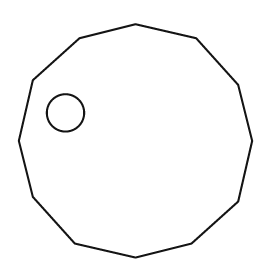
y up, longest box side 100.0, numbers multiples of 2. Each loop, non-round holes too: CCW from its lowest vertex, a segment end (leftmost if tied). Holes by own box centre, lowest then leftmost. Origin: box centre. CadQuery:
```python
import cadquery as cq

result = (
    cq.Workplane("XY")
    .moveTo(0.0, -50.0)
    .lineTo(24.0, -44.0)
    .lineTo(44.0, -26.0)
    .lineTo(50.0, 0.0)
    .lineTo(44.0, 24.0)
    .lineTo(26.0, 44.0)
    .lineTo(0.0, 50.0)
    .lineTo(-24.0, 44.0)
    .lineTo(-44.0, 26.0)
    .lineTo(-50.0, 0.0)
    .lineTo(-44.0, -24.0)
    .lineTo(-26.0, -44.0)
    .close()
    .moveTo(-30.0, 12.0)
    .circle(8.0)
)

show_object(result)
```